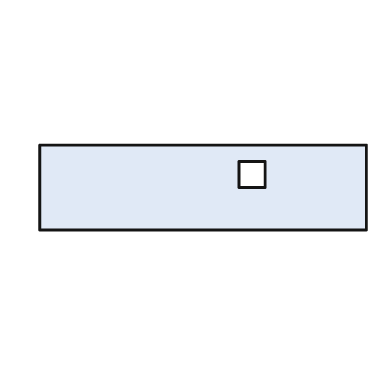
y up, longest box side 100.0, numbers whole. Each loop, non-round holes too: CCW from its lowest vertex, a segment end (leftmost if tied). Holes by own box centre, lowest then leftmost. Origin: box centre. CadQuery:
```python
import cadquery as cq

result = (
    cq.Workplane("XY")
    .moveTo(-50.0, -13.0)
    .lineTo(50.0, -13.0)
    .lineTo(50.0, 13.0)
    .lineTo(-50.0, 13.0)
    .close()
    .moveTo(11.0, 0.0)
    .lineTo(19.0, 0.0)
    .lineTo(19.0, 8.0)
    .lineTo(11.0, 8.0)
    .close()
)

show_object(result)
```